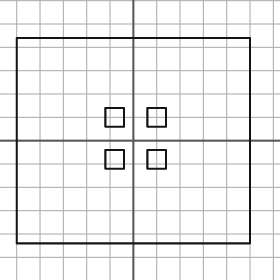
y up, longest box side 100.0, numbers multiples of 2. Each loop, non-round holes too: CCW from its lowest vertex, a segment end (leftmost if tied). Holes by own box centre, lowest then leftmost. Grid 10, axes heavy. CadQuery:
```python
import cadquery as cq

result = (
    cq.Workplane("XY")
    .moveTo(-50.0, -44.0)
    .lineTo(50.0, -44.0)
    .lineTo(50.0, 44.0)
    .lineTo(-50.0, 44.0)
    .close()
    .moveTo(-12.0, -12.0)
    .lineTo(-4.0, -12.0)
    .lineTo(-4.0, -4.0)
    .lineTo(-12.0, -4.0)
    .close()
    .moveTo(6.0, -12.0)
    .lineTo(14.0, -12.0)
    .lineTo(14.0, -4.0)
    .lineTo(6.0, -4.0)
    .close()
    .moveTo(-12.0, 6.0)
    .lineTo(-4.0, 6.0)
    .lineTo(-4.0, 14.0)
    .lineTo(-12.0, 14.0)
    .close()
    .moveTo(6.0, 6.0)
    .lineTo(14.0, 6.0)
    .lineTo(14.0, 14.0)
    .lineTo(6.0, 14.0)
    .close()
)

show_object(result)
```